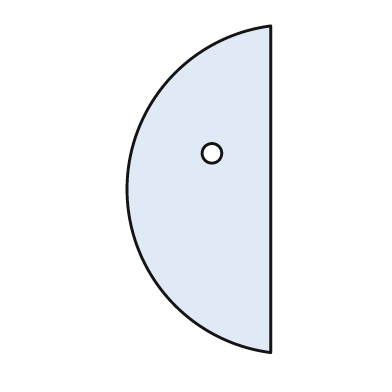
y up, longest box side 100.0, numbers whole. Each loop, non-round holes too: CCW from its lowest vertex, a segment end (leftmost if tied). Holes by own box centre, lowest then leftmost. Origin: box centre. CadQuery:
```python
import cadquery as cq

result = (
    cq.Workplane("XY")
    .moveTo(22.0, -50.0)
    .lineTo(22.0, 50.0)
    .threePointArc((-22.0, 0.0), (22.0, -50.0))
    .close()
    .moveTo(4.0, 11.0)
    .circle(3.0)
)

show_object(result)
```